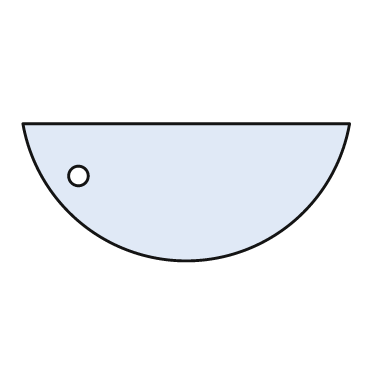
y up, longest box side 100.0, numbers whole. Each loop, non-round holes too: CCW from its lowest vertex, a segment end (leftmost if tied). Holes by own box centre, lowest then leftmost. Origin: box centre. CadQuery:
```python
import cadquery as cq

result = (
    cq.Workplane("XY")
    .moveTo(-50.0, 21.0)
    .threePointArc((0.0, -21.0), (50.0, 21.0))
    .close()
    .moveTo(-33.0, 5.0)
    .circle(3.0)
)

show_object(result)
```